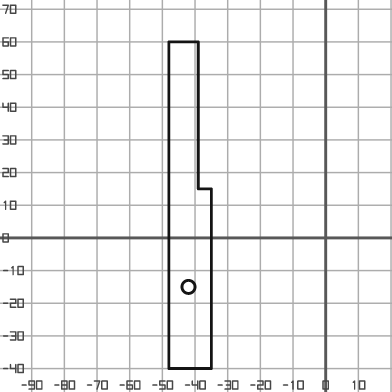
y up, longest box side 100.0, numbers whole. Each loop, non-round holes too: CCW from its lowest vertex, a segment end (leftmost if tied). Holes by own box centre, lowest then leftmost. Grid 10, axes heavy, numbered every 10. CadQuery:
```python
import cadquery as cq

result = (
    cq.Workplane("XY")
    .moveTo(-48.0, -40.0)
    .lineTo(-35.0, -40.0)
    .lineTo(-35.0, 15.0)
    .lineTo(-39.0, 15.0)
    .lineTo(-39.0, 60.0)
    .lineTo(-48.0, 60.0)
    .close()
    .moveTo(-42.0, -15.0)
    .circle(2.0)
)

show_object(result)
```